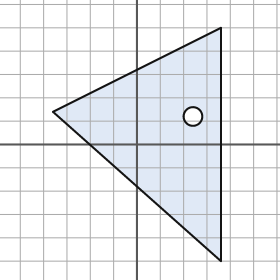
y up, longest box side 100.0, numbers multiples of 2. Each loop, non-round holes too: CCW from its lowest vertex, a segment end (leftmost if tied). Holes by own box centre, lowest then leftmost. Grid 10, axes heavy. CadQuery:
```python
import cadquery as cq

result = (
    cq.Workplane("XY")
    .moveTo(36.0, -50.0)
    .lineTo(36.0, 50.0)
    .lineTo(-36.0, 14.0)
    .close()
    .moveTo(24.0, 12.0)
    .circle(4.0)
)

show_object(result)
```